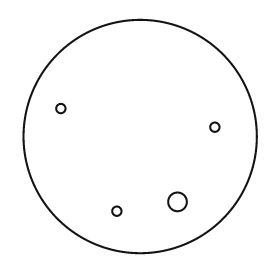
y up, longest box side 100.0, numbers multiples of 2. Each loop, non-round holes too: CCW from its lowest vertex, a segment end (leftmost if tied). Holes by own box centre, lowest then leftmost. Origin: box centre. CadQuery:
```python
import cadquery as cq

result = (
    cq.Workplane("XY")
    .moveTo(0.0, 0.0)
    .circle(50.0)
    .moveTo(-10.0, -32.0)
    .circle(2.0)
    .moveTo(16.0, -28.0)
    .circle(4.0)
    .moveTo(32.0, 4.0)
    .circle(2.0)
    .moveTo(-34.0, 12.0)
    .circle(2.0)
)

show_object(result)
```